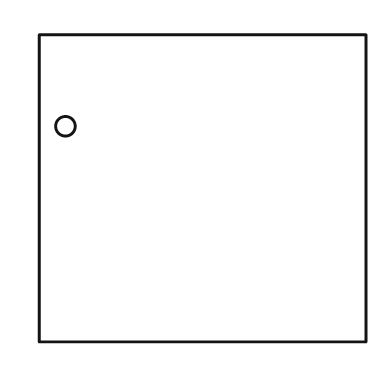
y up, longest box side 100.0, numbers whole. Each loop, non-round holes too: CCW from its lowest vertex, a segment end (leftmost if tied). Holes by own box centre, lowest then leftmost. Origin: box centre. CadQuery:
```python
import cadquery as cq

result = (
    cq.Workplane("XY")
    .moveTo(-50.0, -47.0)
    .lineTo(50.0, -47.0)
    .lineTo(50.0, 47.0)
    .lineTo(-50.0, 47.0)
    .close()
    .moveTo(-42.0, 19.0)
    .circle(3.0)
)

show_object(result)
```